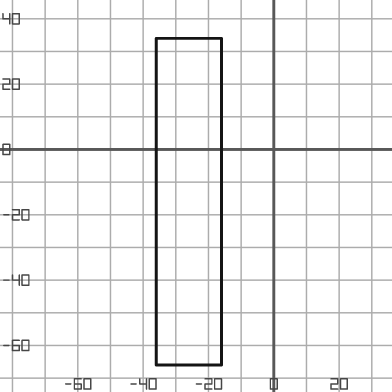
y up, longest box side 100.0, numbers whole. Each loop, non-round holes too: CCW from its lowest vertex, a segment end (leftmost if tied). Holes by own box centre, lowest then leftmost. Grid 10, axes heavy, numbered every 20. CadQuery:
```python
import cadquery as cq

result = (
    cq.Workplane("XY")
    .moveTo(-36.0, -66.0)
    .lineTo(-16.0, -66.0)
    .lineTo(-16.0, 34.0)
    .lineTo(-36.0, 34.0)
    .close()
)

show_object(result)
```